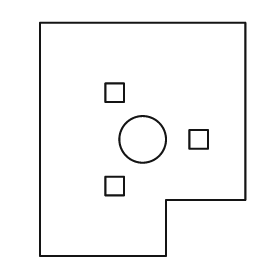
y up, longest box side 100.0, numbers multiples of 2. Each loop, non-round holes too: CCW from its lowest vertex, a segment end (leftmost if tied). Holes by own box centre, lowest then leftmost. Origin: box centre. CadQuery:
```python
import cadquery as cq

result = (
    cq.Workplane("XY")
    .moveTo(-44.0, -50.0)
    .lineTo(10.0, -50.0)
    .lineTo(10.0, -26.0)
    .lineTo(44.0, -26.0)
    .lineTo(44.0, 50.0)
    .lineTo(-44.0, 50.0)
    .close()
    .moveTo(-16.0, -24.0)
    .lineTo(-8.0, -24.0)
    .lineTo(-8.0, -16.0)
    .lineTo(-16.0, -16.0)
    .close()
    .moveTo(0.0, 0.0)
    .circle(10.0)
    .moveTo(20.0, -4.0)
    .lineTo(28.0, -4.0)
    .lineTo(28.0, 4.0)
    .lineTo(20.0, 4.0)
    .close()
    .moveTo(-16.0, 16.0)
    .lineTo(-8.0, 16.0)
    .lineTo(-8.0, 24.0)
    .lineTo(-16.0, 24.0)
    .close()
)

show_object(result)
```